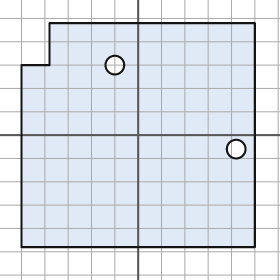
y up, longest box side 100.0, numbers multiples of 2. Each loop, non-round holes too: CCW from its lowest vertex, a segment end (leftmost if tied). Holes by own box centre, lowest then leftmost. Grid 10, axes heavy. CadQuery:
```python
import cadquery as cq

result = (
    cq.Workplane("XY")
    .moveTo(-50.0, -48.0)
    .lineTo(50.0, -48.0)
    .lineTo(50.0, 48.0)
    .lineTo(-38.0, 48.0)
    .lineTo(-38.0, 30.0)
    .lineTo(-50.0, 30.0)
    .close()
    .moveTo(42.0, -6.0)
    .circle(4.0)
    .moveTo(-10.0, 30.0)
    .circle(4.0)
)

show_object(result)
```